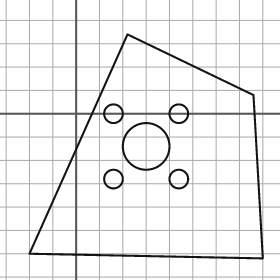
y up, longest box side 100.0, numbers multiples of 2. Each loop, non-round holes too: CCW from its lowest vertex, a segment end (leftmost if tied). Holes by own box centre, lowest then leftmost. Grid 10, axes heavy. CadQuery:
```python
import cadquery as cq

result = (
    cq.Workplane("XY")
    .moveTo(80.0, -62.0)
    .lineTo(76.0, 8.0)
    .lineTo(22.0, 34.0)
    .lineTo(-20.0, -60.0)
    .close()
    .moveTo(16.0, -28.0)
    .circle(4.0)
    .moveTo(44.0, -28.0)
    .circle(4.0)
    .moveTo(30.0, -14.0)
    .circle(10.0)
    .moveTo(16.0, 0.0)
    .circle(4.0)
    .moveTo(44.0, 0.0)
    .circle(4.0)
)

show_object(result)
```